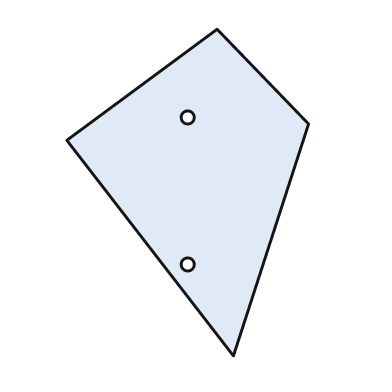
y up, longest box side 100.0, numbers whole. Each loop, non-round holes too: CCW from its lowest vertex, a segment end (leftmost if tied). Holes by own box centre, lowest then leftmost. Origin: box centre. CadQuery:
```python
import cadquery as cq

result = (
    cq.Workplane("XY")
    .moveTo(14.0, -50.0)
    .lineTo(37.0, 21.0)
    .lineTo(9.0, 50.0)
    .lineTo(-37.0, 16.0)
    .close()
    .moveTo(0.0, -22.0)
    .circle(2.0)
    .moveTo(0.0, 23.0)
    .circle(2.0)
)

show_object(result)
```